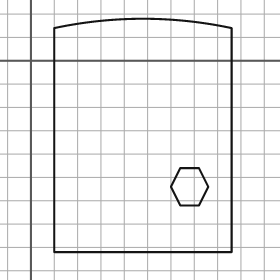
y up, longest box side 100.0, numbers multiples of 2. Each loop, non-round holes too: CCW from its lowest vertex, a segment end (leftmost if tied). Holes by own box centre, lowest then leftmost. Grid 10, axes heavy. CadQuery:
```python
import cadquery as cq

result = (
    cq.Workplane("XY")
    .moveTo(10.0, -82.0)
    .lineTo(86.0, -82.0)
    .lineTo(86.0, 14.0)
    .threePointArc((48.0, 18.0), (10.0, 14.0))
    .close()
    .moveTo(64.0, -62.0)
    .lineTo(72.0, -62.0)
    .lineTo(76.0, -54.0)
    .lineTo(72.0, -46.0)
    .lineTo(64.0, -46.0)
    .lineTo(60.0, -54.0)
    .close()
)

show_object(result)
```